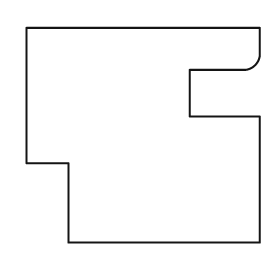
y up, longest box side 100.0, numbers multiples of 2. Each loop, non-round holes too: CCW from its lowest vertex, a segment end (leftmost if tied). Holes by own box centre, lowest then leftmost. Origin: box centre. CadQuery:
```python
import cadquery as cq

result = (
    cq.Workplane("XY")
    .moveTo(-32.0, -46.0)
    .lineTo(50.0, -46.0)
    .lineTo(50.0, 8.0)
    .lineTo(20.0, 8.0)
    .lineTo(20.0, 28.0)
    .lineTo(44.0, 28.0)
    .threePointArc((48.0, 30.0), (50.0, 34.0))
    .lineTo(50.0, 46.0)
    .lineTo(-50.0, 46.0)
    .lineTo(-50.0, -12.0)
    .lineTo(-32.0, -12.0)
    .close()
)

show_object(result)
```